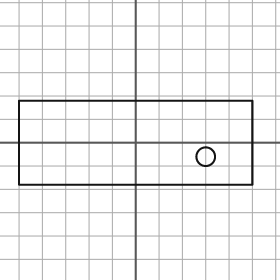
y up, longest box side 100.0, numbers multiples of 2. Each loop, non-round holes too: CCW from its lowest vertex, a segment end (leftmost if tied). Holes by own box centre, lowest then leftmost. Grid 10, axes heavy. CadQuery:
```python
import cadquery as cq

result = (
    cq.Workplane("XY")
    .moveTo(-50.0, -18.0)
    .lineTo(50.0, -18.0)
    .lineTo(50.0, 18.0)
    .lineTo(-50.0, 18.0)
    .close()
    .moveTo(30.0, -6.0)
    .circle(4.0)
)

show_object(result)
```